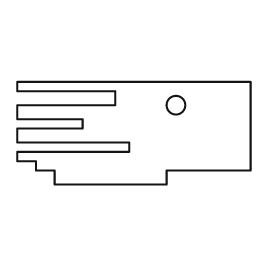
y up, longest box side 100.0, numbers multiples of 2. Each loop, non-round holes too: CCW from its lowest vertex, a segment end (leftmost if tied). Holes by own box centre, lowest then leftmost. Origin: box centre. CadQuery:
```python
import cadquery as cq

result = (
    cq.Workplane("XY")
    .moveTo(-34.0, -22.0)
    .lineTo(14.0, -22.0)
    .lineTo(14.0, -16.0)
    .lineTo(50.0, -16.0)
    .lineTo(50.0, 22.0)
    .lineTo(-50.0, 22.0)
    .lineTo(-50.0, 18.0)
    .lineTo(-8.0, 18.0)
    .lineTo(-8.0, 12.0)
    .lineTo(-50.0, 12.0)
    .lineTo(-50.0, 6.0)
    .lineTo(-22.0, 6.0)
    .lineTo(-22.0, 2.0)
    .lineTo(-50.0, 2.0)
    .lineTo(-50.0, -4.0)
    .lineTo(-2.0, -4.0)
    .lineTo(-2.0, -8.0)
    .lineTo(-50.0, -8.0)
    .lineTo(-50.0, -12.0)
    .lineTo(-42.0, -12.0)
    .lineTo(-42.0, -16.0)
    .lineTo(-34.0, -16.0)
    .close()
    .moveTo(18.0, 12.0)
    .circle(4.0)
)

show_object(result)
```